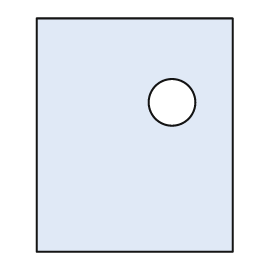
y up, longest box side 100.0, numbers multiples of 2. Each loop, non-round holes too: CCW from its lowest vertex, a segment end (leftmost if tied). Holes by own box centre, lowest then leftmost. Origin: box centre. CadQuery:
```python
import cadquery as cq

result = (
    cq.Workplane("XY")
    .moveTo(-42.0, -50.0)
    .lineTo(42.0, -50.0)
    .lineTo(42.0, 50.0)
    .lineTo(-42.0, 50.0)
    .close()
    .moveTo(16.0, 14.0)
    .circle(10.0)
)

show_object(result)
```